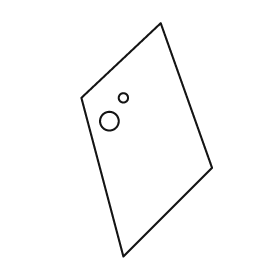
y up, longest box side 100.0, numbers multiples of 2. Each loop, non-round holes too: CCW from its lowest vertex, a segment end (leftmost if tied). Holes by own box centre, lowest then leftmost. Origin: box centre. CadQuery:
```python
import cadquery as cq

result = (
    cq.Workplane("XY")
    .moveTo(-10.0, -50.0)
    .lineTo(28.0, -12.0)
    .lineTo(6.0, 50.0)
    .lineTo(-28.0, 18.0)
    .close()
    .moveTo(-16.0, 8.0)
    .circle(4.0)
    .moveTo(-10.0, 18.0)
    .circle(2.0)
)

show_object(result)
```